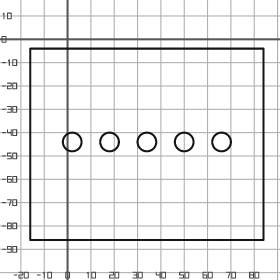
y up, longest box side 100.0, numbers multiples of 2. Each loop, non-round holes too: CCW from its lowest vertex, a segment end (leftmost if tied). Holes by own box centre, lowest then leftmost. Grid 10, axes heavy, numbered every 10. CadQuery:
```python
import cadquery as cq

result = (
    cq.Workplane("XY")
    .moveTo(-16.0, -86.0)
    .lineTo(84.0, -86.0)
    .lineTo(84.0, -4.0)
    .lineTo(-16.0, -4.0)
    .close()
    .moveTo(2.0, -44.0)
    .circle(4.0)
    .moveTo(18.0, -44.0)
    .circle(4.0)
    .moveTo(34.0, -44.0)
    .circle(4.0)
    .moveTo(50.0, -44.0)
    .circle(4.0)
    .moveTo(66.0, -44.0)
    .circle(4.0)
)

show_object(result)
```